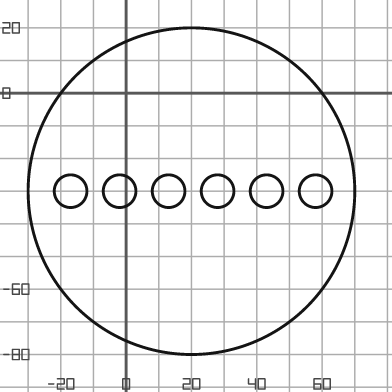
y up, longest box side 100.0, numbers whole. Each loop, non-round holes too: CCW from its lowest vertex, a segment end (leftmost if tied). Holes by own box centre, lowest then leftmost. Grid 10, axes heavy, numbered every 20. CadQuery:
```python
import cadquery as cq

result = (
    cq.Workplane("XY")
    .moveTo(20.0, -30.0)
    .circle(50.0)
    .moveTo(-17.0, -30.0)
    .circle(5.0)
    .moveTo(-2.0, -30.0)
    .circle(5.0)
    .moveTo(13.0, -30.0)
    .circle(5.0)
    .moveTo(28.0, -30.0)
    .circle(5.0)
    .moveTo(43.0, -30.0)
    .circle(5.0)
    .moveTo(58.0, -30.0)
    .circle(5.0)
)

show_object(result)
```